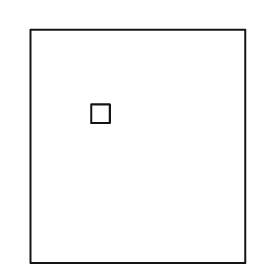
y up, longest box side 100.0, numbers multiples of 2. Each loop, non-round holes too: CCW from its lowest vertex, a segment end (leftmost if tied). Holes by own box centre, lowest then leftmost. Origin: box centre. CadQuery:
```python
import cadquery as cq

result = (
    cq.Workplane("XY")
    .moveTo(-46.0, -50.0)
    .lineTo(46.0, -50.0)
    .lineTo(46.0, 50.0)
    .lineTo(-46.0, 50.0)
    .close()
    .moveTo(-20.0, 10.0)
    .lineTo(-12.0, 10.0)
    .lineTo(-12.0, 18.0)
    .lineTo(-20.0, 18.0)
    .close()
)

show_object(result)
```